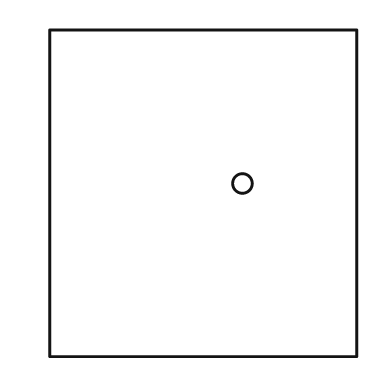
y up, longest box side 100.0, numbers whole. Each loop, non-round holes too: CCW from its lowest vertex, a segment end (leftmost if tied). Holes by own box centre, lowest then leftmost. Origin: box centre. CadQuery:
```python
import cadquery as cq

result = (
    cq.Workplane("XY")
    .moveTo(-47.0, -50.0)
    .lineTo(47.0, -50.0)
    .lineTo(47.0, 50.0)
    .lineTo(-47.0, 50.0)
    .close()
    .moveTo(12.0, 3.0)
    .circle(3.0)
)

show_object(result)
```